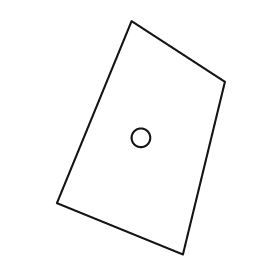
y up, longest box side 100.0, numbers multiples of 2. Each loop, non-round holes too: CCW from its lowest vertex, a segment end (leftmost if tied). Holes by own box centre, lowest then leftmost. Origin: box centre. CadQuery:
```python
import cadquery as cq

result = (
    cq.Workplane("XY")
    .moveTo(18.0, -50.0)
    .lineTo(36.0, 24.0)
    .lineTo(-4.0, 50.0)
    .lineTo(-36.0, -28.0)
    .close()
    .moveTo(0.0, 0.0)
    .circle(4.0)
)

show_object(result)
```